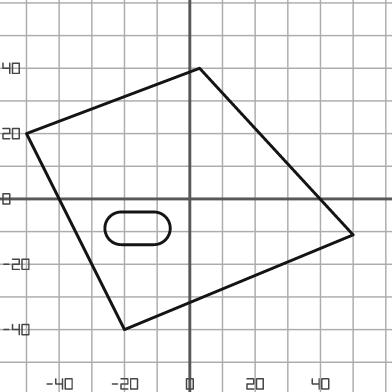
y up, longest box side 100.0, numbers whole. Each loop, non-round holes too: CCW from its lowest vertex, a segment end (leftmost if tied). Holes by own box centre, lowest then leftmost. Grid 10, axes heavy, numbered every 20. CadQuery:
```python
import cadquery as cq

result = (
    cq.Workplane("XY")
    .moveTo(-20.0, -40.0)
    .lineTo(50.0, -11.0)
    .lineTo(3.0, 40.0)
    .lineTo(-50.0, 20.0)
    .close()
    .moveTo(-21.0, -14.0)
    .lineTo(-11.0, -14.0)
    .threePointArc((-6.0, -9.0), (-11.0, -4.0))
    .lineTo(-21.0, -4.0)
    .threePointArc((-26.0, -9.0), (-21.0, -14.0))
    .close()
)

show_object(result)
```